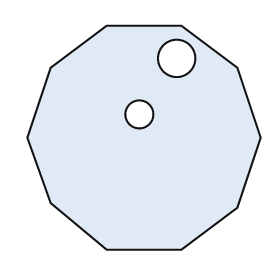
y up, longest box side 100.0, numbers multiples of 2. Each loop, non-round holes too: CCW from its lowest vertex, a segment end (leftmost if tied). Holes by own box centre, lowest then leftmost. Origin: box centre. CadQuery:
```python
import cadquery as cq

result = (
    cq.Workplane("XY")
    .moveTo(-16.0, -48.0)
    .lineTo(16.0, -48.0)
    .lineTo(40.0, -30.0)
    .lineTo(50.0, 0.0)
    .lineTo(40.0, 30.0)
    .lineTo(16.0, 48.0)
    .lineTo(-16.0, 48.0)
    .lineTo(-40.0, 30.0)
    .lineTo(-50.0, 0.0)
    .lineTo(-40.0, -28.0)
    .close()
    .moveTo(-2.0, 10.0)
    .circle(6.0)
    .moveTo(14.0, 34.0)
    .circle(8.0)
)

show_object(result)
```